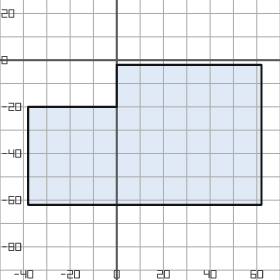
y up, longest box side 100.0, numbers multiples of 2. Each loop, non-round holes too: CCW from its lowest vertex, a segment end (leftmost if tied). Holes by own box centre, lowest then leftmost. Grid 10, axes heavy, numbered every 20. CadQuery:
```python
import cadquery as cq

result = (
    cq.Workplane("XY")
    .moveTo(-38.0, -62.0)
    .lineTo(62.0, -62.0)
    .lineTo(62.0, -2.0)
    .lineTo(0.0, -2.0)
    .lineTo(0.0, -20.0)
    .lineTo(-38.0, -20.0)
    .close()
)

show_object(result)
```